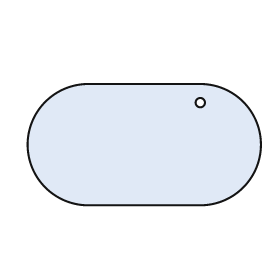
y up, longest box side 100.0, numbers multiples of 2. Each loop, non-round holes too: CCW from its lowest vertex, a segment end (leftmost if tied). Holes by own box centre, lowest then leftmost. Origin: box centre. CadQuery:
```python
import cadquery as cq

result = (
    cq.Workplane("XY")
    .moveTo(-24.0, -26.0)
    .lineTo(24.0, -26.0)
    .threePointArc((50.0, 0.0), (24.0, 26.0))
    .lineTo(-24.0, 26.0)
    .threePointArc((-50.0, 0.0), (-24.0, -26.0))
    .close()
    .moveTo(24.0, 18.0)
    .circle(2.0)
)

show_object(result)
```